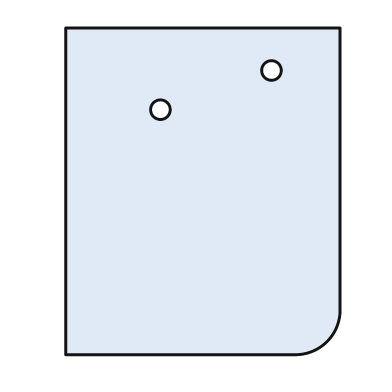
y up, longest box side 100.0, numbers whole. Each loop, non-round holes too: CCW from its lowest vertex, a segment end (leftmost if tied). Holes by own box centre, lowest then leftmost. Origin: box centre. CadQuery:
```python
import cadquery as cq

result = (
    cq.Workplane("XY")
    .moveTo(-42.0, -50.0)
    .lineTo(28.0, -50.0)
    .threePointArc((38.0, -46.0), (42.0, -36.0))
    .lineTo(42.0, 50.0)
    .lineTo(-42.0, 50.0)
    .close()
    .moveTo(-13.0, 25.0)
    .circle(3.0)
    .moveTo(21.0, 37.0)
    .circle(3.0)
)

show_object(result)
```